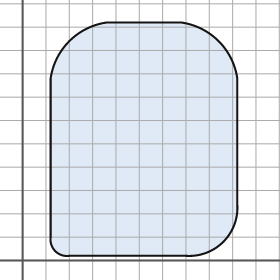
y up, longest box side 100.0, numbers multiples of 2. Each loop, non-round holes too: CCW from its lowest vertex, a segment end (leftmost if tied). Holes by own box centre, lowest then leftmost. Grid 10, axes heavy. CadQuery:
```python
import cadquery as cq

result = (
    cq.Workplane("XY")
    .moveTo(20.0, 2.0)
    .lineTo(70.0, 2.0)
    .threePointArc((86.0, 8.0), (92.0, 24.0))
    .lineTo(92.0, 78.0)
    .threePointArc((84.0, 94.0), (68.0, 102.0))
    .lineTo(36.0, 102.0)
    .threePointArc((20.0, 94.0), (12.0, 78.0))
    .lineTo(12.0, 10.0)
    .threePointArc((14.0, 4.0), (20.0, 2.0))
    .close()
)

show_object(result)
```